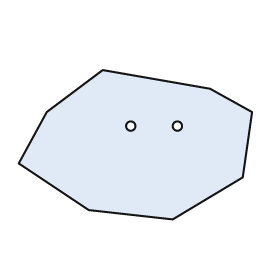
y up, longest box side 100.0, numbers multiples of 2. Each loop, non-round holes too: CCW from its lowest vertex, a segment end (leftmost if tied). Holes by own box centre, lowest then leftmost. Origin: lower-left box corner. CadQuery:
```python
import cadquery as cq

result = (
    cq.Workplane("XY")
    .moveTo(66.0, 0.0)
    .lineTo(96.0, 18.0)
    .lineTo(100.0, 46.0)
    .lineTo(82.0, 56.0)
    .lineTo(36.0, 64.0)
    .lineTo(12.0, 46.0)
    .lineTo(0.0, 24.0)
    .lineTo(30.0, 4.0)
    .close()
    .moveTo(48.0, 40.0)
    .circle(2.0)
    .moveTo(68.0, 40.0)
    .circle(2.0)
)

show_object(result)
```